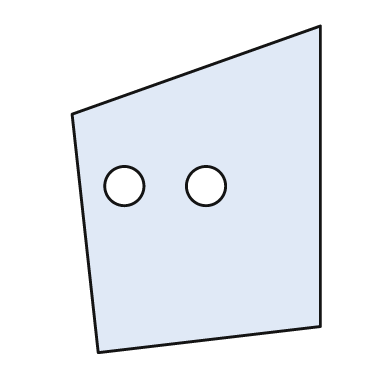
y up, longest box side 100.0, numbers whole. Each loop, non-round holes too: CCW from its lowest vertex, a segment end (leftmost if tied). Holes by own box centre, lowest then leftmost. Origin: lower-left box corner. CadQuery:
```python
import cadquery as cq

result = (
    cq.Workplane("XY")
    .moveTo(8.0, 0.0)
    .lineTo(76.0, 8.0)
    .lineTo(76.0, 100.0)
    .lineTo(0.0, 73.0)
    .close()
    .moveTo(16.0, 51.0)
    .circle(6.0)
    .moveTo(41.0, 51.0)
    .circle(6.0)
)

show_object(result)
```